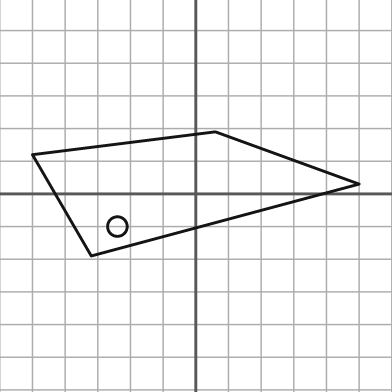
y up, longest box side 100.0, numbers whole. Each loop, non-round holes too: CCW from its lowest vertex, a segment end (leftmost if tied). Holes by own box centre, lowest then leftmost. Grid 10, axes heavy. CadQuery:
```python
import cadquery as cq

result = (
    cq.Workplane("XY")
    .moveTo(-32.0, -19.0)
    .lineTo(50.0, 3.0)
    .lineTo(6.0, 19.0)
    .lineTo(-50.0, 12.0)
    .close()
    .moveTo(-24.0, -10.0)
    .circle(3.0)
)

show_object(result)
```